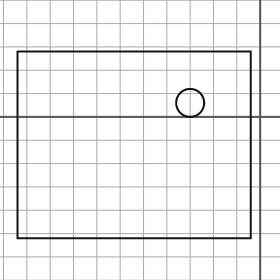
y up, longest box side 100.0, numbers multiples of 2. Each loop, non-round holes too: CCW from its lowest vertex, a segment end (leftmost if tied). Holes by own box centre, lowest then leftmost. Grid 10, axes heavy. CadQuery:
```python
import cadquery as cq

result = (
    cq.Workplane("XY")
    .moveTo(-104.0, -52.0)
    .lineTo(-4.0, -52.0)
    .lineTo(-4.0, 28.0)
    .lineTo(-104.0, 28.0)
    .close()
    .moveTo(-30.0, 6.0)
    .circle(6.0)
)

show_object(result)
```